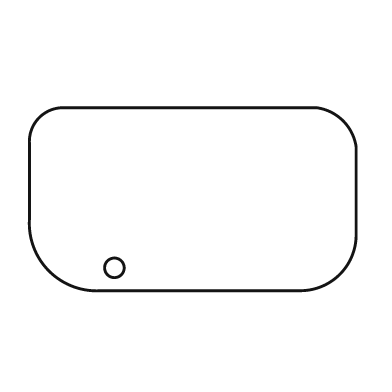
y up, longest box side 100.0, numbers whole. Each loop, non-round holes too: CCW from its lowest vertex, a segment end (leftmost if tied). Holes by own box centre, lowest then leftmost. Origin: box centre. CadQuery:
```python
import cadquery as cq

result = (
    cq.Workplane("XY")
    .moveTo(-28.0, -28.0)
    .lineTo(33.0, -28.0)
    .threePointArc((45.0, -23.0), (50.0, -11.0))
    .lineTo(50.0, 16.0)
    .threePointArc((46.0, 24.0), (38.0, 28.0))
    .lineTo(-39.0, 28.0)
    .threePointArc((-47.0, 25.0), (-50.0, 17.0))
    .lineTo(-50.0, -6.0)
    .threePointArc((-44.0, -22.0), (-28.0, -28.0))
    .close()
    .moveTo(-24.0, -21.0)
    .circle(3.0)
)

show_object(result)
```